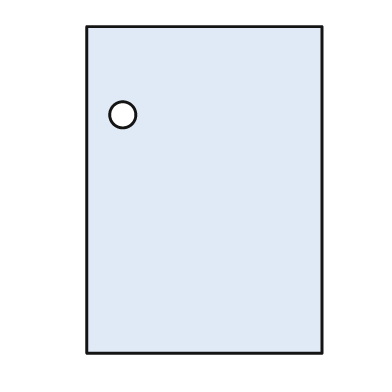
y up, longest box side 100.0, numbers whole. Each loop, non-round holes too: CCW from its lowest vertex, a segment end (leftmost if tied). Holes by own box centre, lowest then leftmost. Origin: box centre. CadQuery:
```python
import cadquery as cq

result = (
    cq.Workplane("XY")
    .moveTo(-36.0, -50.0)
    .lineTo(36.0, -50.0)
    .lineTo(36.0, 50.0)
    .lineTo(-36.0, 50.0)
    .close()
    .moveTo(-25.0, 23.0)
    .circle(4.0)
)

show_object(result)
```